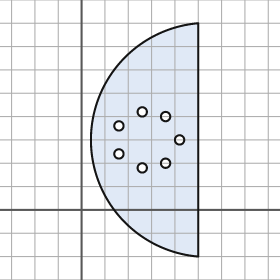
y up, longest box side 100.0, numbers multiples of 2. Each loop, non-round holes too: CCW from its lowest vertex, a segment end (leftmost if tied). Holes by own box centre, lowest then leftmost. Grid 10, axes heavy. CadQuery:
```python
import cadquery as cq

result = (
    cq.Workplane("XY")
    .moveTo(50.0, -20.0)
    .lineTo(50.0, 80.0)
    .threePointArc((4.0, 30.0), (50.0, -20.0))
    .close()
    .moveTo(26.0, 18.0)
    .circle(2.0)
    .moveTo(36.0, 20.0)
    .circle(2.0)
    .moveTo(16.0, 24.0)
    .circle(2.0)
    .moveTo(42.0, 30.0)
    .circle(2.0)
    .moveTo(16.0, 36.0)
    .circle(2.0)
    .moveTo(36.0, 40.0)
    .circle(2.0)
    .moveTo(26.0, 42.0)
    .circle(2.0)
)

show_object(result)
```